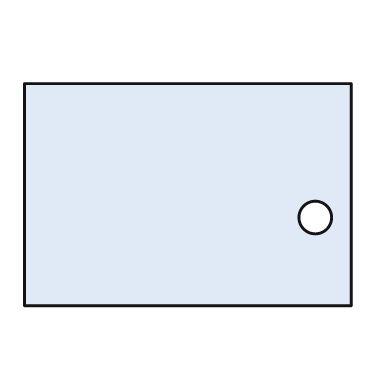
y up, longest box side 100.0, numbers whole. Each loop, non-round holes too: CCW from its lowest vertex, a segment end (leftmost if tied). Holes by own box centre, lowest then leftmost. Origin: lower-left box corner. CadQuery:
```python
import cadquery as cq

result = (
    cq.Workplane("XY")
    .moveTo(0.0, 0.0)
    .lineTo(100.0, 0.0)
    .lineTo(100.0, 68.0)
    .lineTo(0.0, 68.0)
    .close()
    .moveTo(89.0, 27.0)
    .circle(5.0)
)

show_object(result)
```